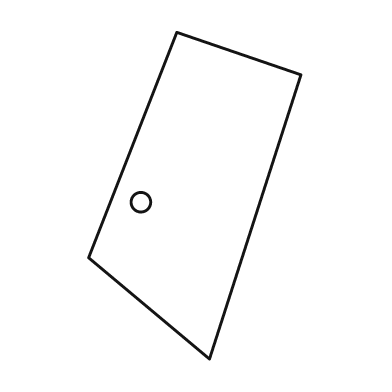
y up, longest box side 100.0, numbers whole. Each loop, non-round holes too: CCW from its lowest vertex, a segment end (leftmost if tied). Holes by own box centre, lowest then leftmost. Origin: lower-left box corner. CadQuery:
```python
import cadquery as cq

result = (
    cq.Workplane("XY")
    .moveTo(37.0, 0.0)
    .lineTo(65.0, 87.0)
    .lineTo(27.0, 100.0)
    .lineTo(0.0, 31.0)
    .close()
    .moveTo(16.0, 48.0)
    .circle(3.0)
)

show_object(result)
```